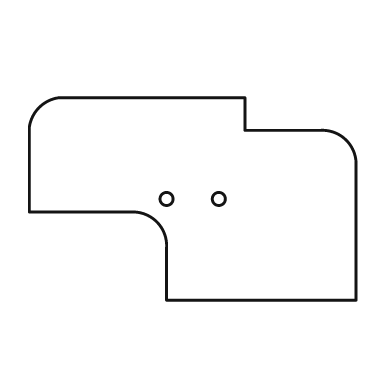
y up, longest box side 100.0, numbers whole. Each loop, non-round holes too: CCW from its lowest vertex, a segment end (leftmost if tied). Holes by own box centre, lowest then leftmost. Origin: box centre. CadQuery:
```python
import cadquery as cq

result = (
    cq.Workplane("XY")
    .moveTo(-8.0, -31.0)
    .lineTo(50.0, -31.0)
    .lineTo(50.0, 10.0)
    .threePointArc((47.0, 18.0), (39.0, 21.0))
    .lineTo(16.0, 21.0)
    .lineTo(16.0, 31.0)
    .lineTo(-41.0, 31.0)
    .threePointArc((-47.0, 28.0), (-50.0, 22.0))
    .lineTo(-50.0, -4.0)
    .lineTo(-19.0, -4.0)
    .threePointArc((-11.0, -7.0), (-8.0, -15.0))
    .close()
    .moveTo(-8.0, 0.0)
    .circle(2.0)
    .moveTo(8.0, 0.0)
    .circle(2.0)
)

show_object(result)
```